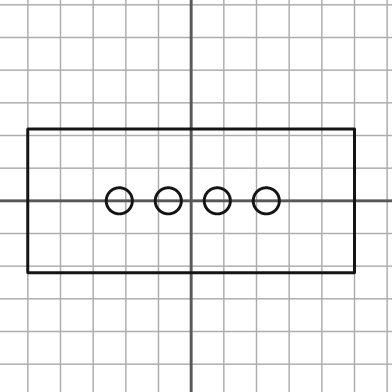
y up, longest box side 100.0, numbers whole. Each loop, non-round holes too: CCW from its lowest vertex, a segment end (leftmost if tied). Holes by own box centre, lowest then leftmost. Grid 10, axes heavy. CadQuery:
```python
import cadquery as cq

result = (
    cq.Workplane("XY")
    .moveTo(-50.0, -22.0)
    .lineTo(50.0, -22.0)
    .lineTo(50.0, 22.0)
    .lineTo(-50.0, 22.0)
    .close()
    .moveTo(-22.0, 0.0)
    .circle(4.0)
    .moveTo(-7.0, 0.0)
    .circle(4.0)
    .moveTo(8.0, 0.0)
    .circle(4.0)
    .moveTo(23.0, 0.0)
    .circle(4.0)
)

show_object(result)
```